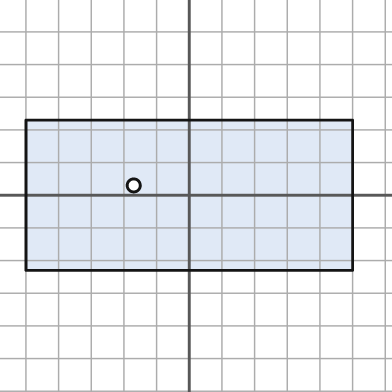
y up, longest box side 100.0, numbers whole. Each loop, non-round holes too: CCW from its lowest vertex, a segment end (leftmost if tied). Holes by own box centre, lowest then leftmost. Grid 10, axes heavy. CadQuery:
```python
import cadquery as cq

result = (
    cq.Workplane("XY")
    .moveTo(-50.0, -23.0)
    .lineTo(50.0, -23.0)
    .lineTo(50.0, 23.0)
    .lineTo(-50.0, 23.0)
    .close()
    .moveTo(-17.0, 3.0)
    .circle(2.0)
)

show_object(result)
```